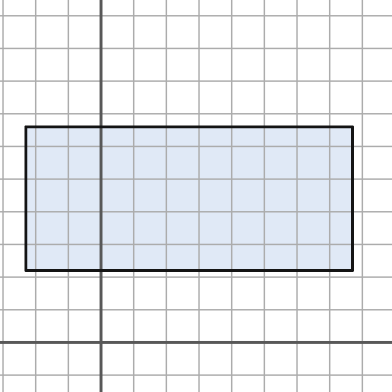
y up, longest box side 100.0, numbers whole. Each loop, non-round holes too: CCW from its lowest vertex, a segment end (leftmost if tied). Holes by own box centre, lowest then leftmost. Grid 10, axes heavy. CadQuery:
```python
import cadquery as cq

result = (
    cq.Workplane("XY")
    .moveTo(-23.0, 22.0)
    .lineTo(77.0, 22.0)
    .lineTo(77.0, 66.0)
    .lineTo(-23.0, 66.0)
    .close()
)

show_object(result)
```